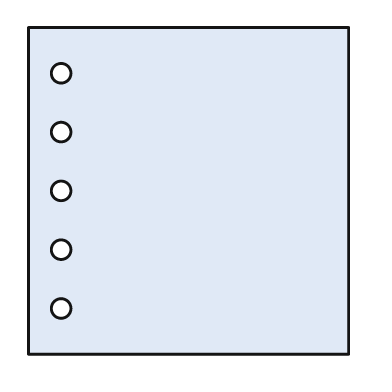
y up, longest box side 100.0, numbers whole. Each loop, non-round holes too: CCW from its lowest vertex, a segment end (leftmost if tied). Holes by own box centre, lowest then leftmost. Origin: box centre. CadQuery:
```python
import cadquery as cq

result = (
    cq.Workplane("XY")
    .moveTo(-49.0, -50.0)
    .lineTo(49.0, -50.0)
    .lineTo(49.0, 50.0)
    .lineTo(-49.0, 50.0)
    .close()
    .moveTo(-39.0, -36.0)
    .circle(3.0)
    .moveTo(-39.0, -18.0)
    .circle(3.0)
    .moveTo(-39.0, 0.0)
    .circle(3.0)
    .moveTo(-39.0, 18.0)
    .circle(3.0)
    .moveTo(-39.0, 36.0)
    .circle(3.0)
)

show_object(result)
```